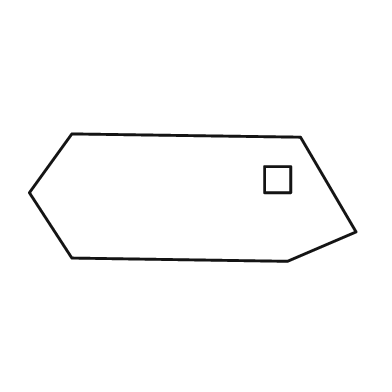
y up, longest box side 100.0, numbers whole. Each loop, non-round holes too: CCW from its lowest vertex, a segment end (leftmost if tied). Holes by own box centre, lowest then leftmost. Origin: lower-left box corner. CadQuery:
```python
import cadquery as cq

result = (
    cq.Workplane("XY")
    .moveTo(79.0, 0.0)
    .lineTo(100.0, 9.0)
    .lineTo(83.0, 38.0)
    .lineTo(13.0, 39.0)
    .lineTo(0.0, 21.0)
    .lineTo(13.0, 1.0)
    .close()
    .moveTo(72.0, 21.0)
    .lineTo(80.0, 21.0)
    .lineTo(80.0, 29.0)
    .lineTo(72.0, 29.0)
    .close()
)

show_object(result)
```